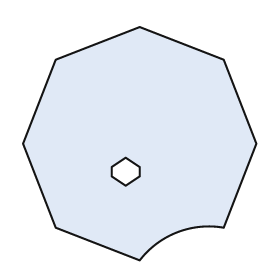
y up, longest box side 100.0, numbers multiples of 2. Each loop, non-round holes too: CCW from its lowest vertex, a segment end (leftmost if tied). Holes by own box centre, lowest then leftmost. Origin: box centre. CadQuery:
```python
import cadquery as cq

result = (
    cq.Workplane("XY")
    .moveTo(0.0, -50.0)
    .threePointArc((16.0, -38.0), (36.0, -36.0))
    .lineTo(50.0, 0.0)
    .lineTo(36.0, 36.0)
    .lineTo(0.0, 50.0)
    .lineTo(-36.0, 36.0)
    .lineTo(-50.0, 0.0)
    .lineTo(-36.0, -36.0)
    .close()
    .moveTo(-6.0, -18.0)
    .lineTo(0.0, -14.0)
    .lineTo(0.0, -10.0)
    .lineTo(-6.0, -6.0)
    .lineTo(-12.0, -10.0)
    .lineTo(-12.0, -14.0)
    .close()
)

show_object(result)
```